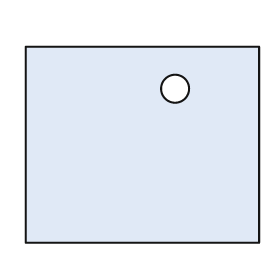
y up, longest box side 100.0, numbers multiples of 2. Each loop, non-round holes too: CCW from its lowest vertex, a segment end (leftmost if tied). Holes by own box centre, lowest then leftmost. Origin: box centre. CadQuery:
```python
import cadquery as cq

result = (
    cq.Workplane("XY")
    .moveTo(-50.0, -42.0)
    .lineTo(50.0, -42.0)
    .lineTo(50.0, 42.0)
    .lineTo(-50.0, 42.0)
    .close()
    .moveTo(14.0, 24.0)
    .circle(6.0)
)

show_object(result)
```